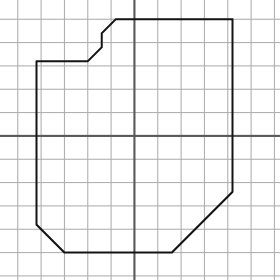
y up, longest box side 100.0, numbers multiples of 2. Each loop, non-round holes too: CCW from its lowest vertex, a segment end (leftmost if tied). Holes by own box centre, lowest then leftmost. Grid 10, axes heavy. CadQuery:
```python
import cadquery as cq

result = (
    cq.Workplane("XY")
    .moveTo(-30.0, -50.0)
    .lineTo(16.0, -50.0)
    .lineTo(42.0, -24.0)
    .lineTo(42.0, 50.0)
    .lineTo(-8.0, 50.0)
    .lineTo(-14.0, 44.0)
    .lineTo(-14.0, 38.0)
    .lineTo(-20.0, 32.0)
    .lineTo(-42.0, 32.0)
    .lineTo(-42.0, -38.0)
    .close()
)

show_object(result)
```